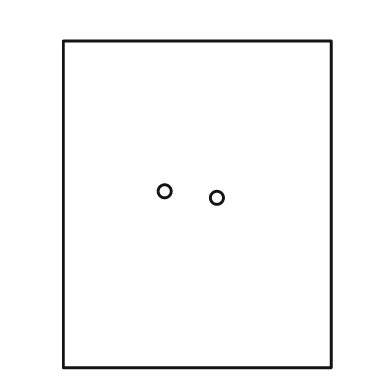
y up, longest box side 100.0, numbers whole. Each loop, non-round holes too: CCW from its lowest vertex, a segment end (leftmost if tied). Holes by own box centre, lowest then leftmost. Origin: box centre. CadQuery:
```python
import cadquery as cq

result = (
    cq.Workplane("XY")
    .moveTo(-41.0, -50.0)
    .lineTo(41.0, -50.0)
    .lineTo(41.0, 50.0)
    .lineTo(-41.0, 50.0)
    .close()
    .moveTo(6.0, 2.0)
    .circle(2.0)
    .moveTo(-10.0, 4.0)
    .circle(2.0)
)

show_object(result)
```